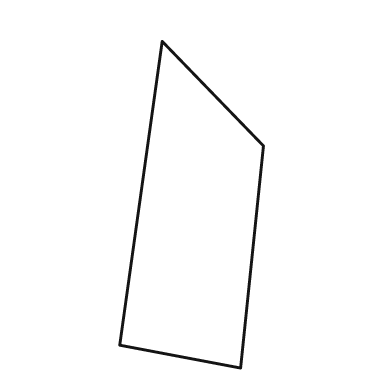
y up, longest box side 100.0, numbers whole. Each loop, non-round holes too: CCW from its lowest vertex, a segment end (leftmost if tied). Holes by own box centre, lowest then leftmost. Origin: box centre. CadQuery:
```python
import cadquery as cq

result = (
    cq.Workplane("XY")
    .moveTo(15.0, -50.0)
    .lineTo(22.0, 18.0)
    .lineTo(-9.0, 50.0)
    .lineTo(-22.0, -43.0)
    .close()
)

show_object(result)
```